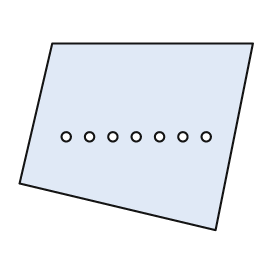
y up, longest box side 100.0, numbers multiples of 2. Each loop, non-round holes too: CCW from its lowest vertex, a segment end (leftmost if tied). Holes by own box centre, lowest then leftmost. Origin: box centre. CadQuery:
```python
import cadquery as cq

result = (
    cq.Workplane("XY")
    .moveTo(34.0, -40.0)
    .lineTo(50.0, 40.0)
    .lineTo(-36.0, 40.0)
    .lineTo(-50.0, -20.0)
    .close()
    .moveTo(-30.0, 0.0)
    .circle(2.0)
    .moveTo(-20.0, 0.0)
    .circle(2.0)
    .moveTo(-10.0, 0.0)
    .circle(2.0)
    .moveTo(0.0, 0.0)
    .circle(2.0)
    .moveTo(10.0, 0.0)
    .circle(2.0)
    .moveTo(20.0, 0.0)
    .circle(2.0)
    .moveTo(30.0, 0.0)
    .circle(2.0)
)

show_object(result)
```